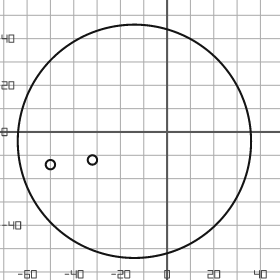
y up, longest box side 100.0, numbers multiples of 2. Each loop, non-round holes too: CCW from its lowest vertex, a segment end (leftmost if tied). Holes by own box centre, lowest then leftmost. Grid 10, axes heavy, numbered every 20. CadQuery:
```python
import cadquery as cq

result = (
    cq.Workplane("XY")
    .moveTo(-14.0, -4.0)
    .circle(50.0)
    .moveTo(-50.0, -14.0)
    .circle(2.0)
    .moveTo(-32.0, -12.0)
    .circle(2.0)
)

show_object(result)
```